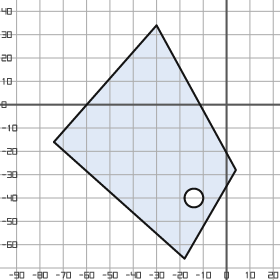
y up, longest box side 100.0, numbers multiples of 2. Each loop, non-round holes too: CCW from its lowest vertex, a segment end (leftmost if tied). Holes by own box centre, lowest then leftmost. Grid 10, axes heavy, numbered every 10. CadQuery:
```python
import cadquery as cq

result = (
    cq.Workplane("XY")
    .moveTo(-18.0, -66.0)
    .lineTo(4.0, -28.0)
    .lineTo(-30.0, 34.0)
    .lineTo(-74.0, -16.0)
    .close()
    .moveTo(-14.0, -40.0)
    .circle(4.0)
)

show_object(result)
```